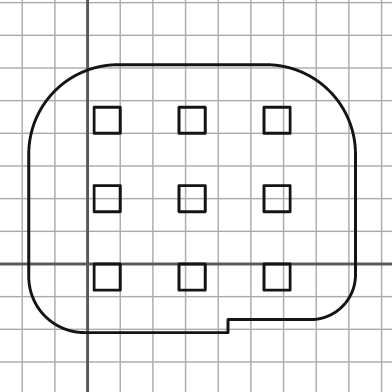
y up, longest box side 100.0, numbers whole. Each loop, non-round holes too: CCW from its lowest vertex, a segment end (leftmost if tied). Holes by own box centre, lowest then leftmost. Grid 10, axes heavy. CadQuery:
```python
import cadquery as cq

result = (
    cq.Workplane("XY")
    .moveTo(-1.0, -21.0)
    .lineTo(43.0, -21.0)
    .lineTo(43.0, -17.0)
    .lineTo(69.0, -17.0)
    .threePointArc((78.0, -13.0), (82.0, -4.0))
    .lineTo(82.0, 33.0)
    .threePointArc((74.0, 53.0), (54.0, 61.0))
    .lineTo(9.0, 61.0)
    .threePointArc((-10.0, 53.0), (-18.0, 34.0))
    .lineTo(-18.0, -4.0)
    .threePointArc((-13.0, -16.0), (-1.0, -21.0))
    .close()
    .moveTo(2.0, -8.0)
    .lineTo(10.0, -8.0)
    .lineTo(10.0, 0.0)
    .lineTo(2.0, 0.0)
    .close()
    .moveTo(28.0, -8.0)
    .lineTo(36.0, -8.0)
    .lineTo(36.0, 0.0)
    .lineTo(28.0, 0.0)
    .close()
    .moveTo(54.0, -8.0)
    .lineTo(62.0, -8.0)
    .lineTo(62.0, 0.0)
    .lineTo(54.0, 0.0)
    .close()
    .moveTo(2.0, 16.0)
    .lineTo(10.0, 16.0)
    .lineTo(10.0, 24.0)
    .lineTo(2.0, 24.0)
    .close()
    .moveTo(28.0, 16.0)
    .lineTo(36.0, 16.0)
    .lineTo(36.0, 24.0)
    .lineTo(28.0, 24.0)
    .close()
    .moveTo(54.0, 16.0)
    .lineTo(62.0, 16.0)
    .lineTo(62.0, 24.0)
    .lineTo(54.0, 24.0)
    .close()
    .moveTo(2.0, 40.0)
    .lineTo(10.0, 40.0)
    .lineTo(10.0, 48.0)
    .lineTo(2.0, 48.0)
    .close()
    .moveTo(28.0, 40.0)
    .lineTo(36.0, 40.0)
    .lineTo(36.0, 48.0)
    .lineTo(28.0, 48.0)
    .close()
    .moveTo(54.0, 40.0)
    .lineTo(62.0, 40.0)
    .lineTo(62.0, 48.0)
    .lineTo(54.0, 48.0)
    .close()
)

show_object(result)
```